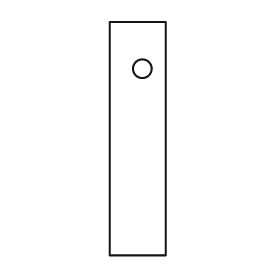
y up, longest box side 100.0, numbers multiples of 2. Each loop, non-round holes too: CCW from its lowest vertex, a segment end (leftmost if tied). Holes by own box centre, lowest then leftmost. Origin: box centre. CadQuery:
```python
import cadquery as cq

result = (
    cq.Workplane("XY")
    .moveTo(-12.0, -50.0)
    .lineTo(12.0, -50.0)
    .lineTo(12.0, 50.0)
    .lineTo(-12.0, 50.0)
    .close()
    .moveTo(2.0, 30.0)
    .circle(4.0)
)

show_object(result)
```